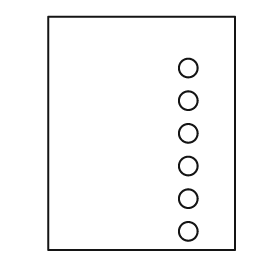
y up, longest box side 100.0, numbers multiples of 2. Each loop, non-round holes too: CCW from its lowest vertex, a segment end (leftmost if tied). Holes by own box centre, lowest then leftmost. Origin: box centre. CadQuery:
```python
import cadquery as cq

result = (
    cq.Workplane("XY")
    .moveTo(-40.0, -50.0)
    .lineTo(40.0, -50.0)
    .lineTo(40.0, 50.0)
    .lineTo(-40.0, 50.0)
    .close()
    .moveTo(20.0, -42.0)
    .circle(4.0)
    .moveTo(20.0, -28.0)
    .circle(4.0)
    .moveTo(20.0, -14.0)
    .circle(4.0)
    .moveTo(20.0, 0.0)
    .circle(4.0)
    .moveTo(20.0, 14.0)
    .circle(4.0)
    .moveTo(20.0, 28.0)
    .circle(4.0)
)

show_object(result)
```